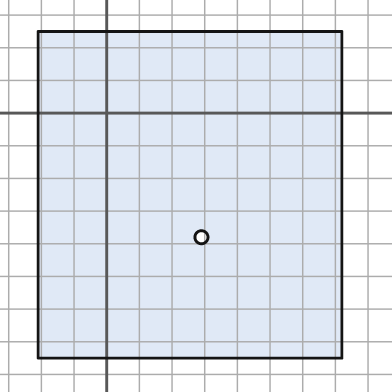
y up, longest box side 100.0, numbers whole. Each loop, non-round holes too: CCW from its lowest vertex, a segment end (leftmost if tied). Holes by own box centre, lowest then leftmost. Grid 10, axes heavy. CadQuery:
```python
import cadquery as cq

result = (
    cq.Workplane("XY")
    .moveTo(-21.0, -75.0)
    .lineTo(72.0, -75.0)
    .lineTo(72.0, 25.0)
    .lineTo(-21.0, 25.0)
    .close()
    .moveTo(29.0, -38.0)
    .circle(2.0)
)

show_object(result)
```